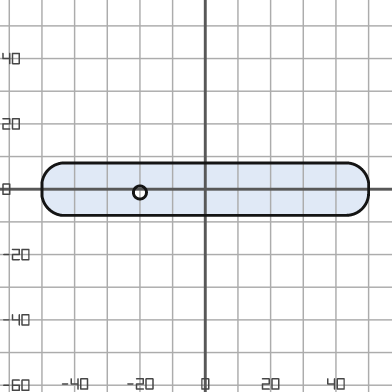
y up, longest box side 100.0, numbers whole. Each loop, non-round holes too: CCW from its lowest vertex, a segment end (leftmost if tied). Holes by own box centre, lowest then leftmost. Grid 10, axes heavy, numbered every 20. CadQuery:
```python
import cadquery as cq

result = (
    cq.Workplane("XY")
    .moveTo(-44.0, -8.0)
    .lineTo(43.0, -8.0)
    .threePointArc((48.0, -6.0), (50.0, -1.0))
    .lineTo(50.0, 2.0)
    .threePointArc((48.0, 6.0), (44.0, 8.0))
    .lineTo(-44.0, 8.0)
    .threePointArc((-48.0, 6.0), (-50.0, 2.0))
    .lineTo(-50.0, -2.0)
    .threePointArc((-48.0, -6.0), (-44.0, -8.0))
    .close()
    .moveTo(-20.0, -1.0)
    .circle(2.0)
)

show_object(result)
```